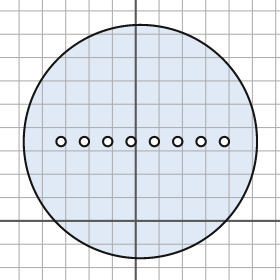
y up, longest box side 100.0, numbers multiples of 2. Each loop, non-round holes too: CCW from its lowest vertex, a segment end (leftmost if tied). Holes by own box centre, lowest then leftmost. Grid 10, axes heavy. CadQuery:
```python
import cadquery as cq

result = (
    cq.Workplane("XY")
    .moveTo(2.0, 34.0)
    .circle(50.0)
    .moveTo(-32.0, 34.0)
    .circle(2.0)
    .moveTo(-22.0, 34.0)
    .circle(2.0)
    .moveTo(-12.0, 34.0)
    .circle(2.0)
    .moveTo(-2.0, 34.0)
    .circle(2.0)
    .moveTo(8.0, 34.0)
    .circle(2.0)
    .moveTo(18.0, 34.0)
    .circle(2.0)
    .moveTo(28.0, 34.0)
    .circle(2.0)
    .moveTo(38.0, 34.0)
    .circle(2.0)
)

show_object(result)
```